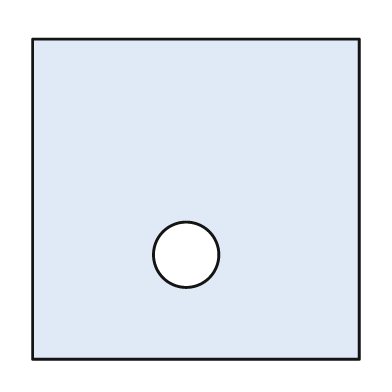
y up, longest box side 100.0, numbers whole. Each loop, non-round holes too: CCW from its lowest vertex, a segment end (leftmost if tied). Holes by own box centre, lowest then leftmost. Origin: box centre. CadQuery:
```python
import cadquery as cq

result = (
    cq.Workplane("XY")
    .moveTo(-50.0, -49.0)
    .lineTo(50.0, -49.0)
    .lineTo(50.0, 49.0)
    .lineTo(-50.0, 49.0)
    .close()
    .moveTo(-3.0, -17.0)
    .circle(10.0)
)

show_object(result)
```